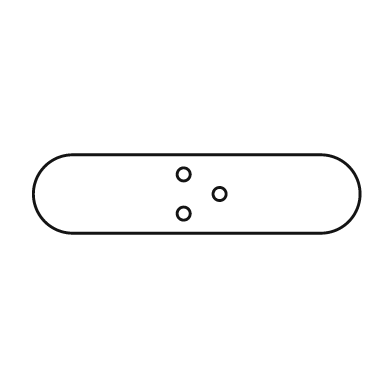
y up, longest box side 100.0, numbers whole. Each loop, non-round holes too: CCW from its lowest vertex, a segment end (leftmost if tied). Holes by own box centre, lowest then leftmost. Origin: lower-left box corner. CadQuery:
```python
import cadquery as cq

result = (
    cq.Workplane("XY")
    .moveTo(12.0, 0.0)
    .lineTo(88.0, 0.0)
    .threePointArc((100.0, 12.0), (88.0, 24.0))
    .lineTo(12.0, 24.0)
    .threePointArc((0.0, 12.0), (12.0, 0.0))
    .close()
    .moveTo(46.0, 6.0)
    .circle(2.0)
    .moveTo(57.0, 12.0)
    .circle(2.0)
    .moveTo(46.0, 18.0)
    .circle(2.0)
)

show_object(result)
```